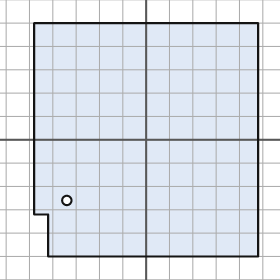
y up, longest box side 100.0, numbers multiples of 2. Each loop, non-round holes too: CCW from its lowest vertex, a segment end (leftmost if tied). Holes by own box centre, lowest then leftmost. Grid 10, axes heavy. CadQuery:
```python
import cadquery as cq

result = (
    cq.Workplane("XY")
    .moveTo(-42.0, -50.0)
    .lineTo(48.0, -50.0)
    .lineTo(48.0, 50.0)
    .lineTo(-48.0, 50.0)
    .lineTo(-48.0, -32.0)
    .lineTo(-42.0, -32.0)
    .close()
    .moveTo(-34.0, -26.0)
    .circle(2.0)
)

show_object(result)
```